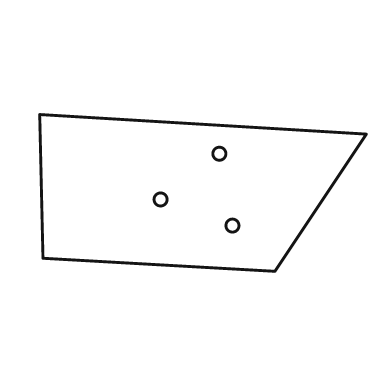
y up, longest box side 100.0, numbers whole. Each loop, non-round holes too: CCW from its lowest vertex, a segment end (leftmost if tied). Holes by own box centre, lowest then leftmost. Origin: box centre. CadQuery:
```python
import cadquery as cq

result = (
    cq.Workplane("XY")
    .moveTo(22.0, -24.0)
    .lineTo(50.0, 18.0)
    .lineTo(-50.0, 24.0)
    .lineTo(-49.0, -20.0)
    .close()
    .moveTo(9.0, -10.0)
    .circle(2.0)
    .moveTo(-13.0, -2.0)
    .circle(2.0)
    .moveTo(5.0, 12.0)
    .circle(2.0)
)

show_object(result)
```